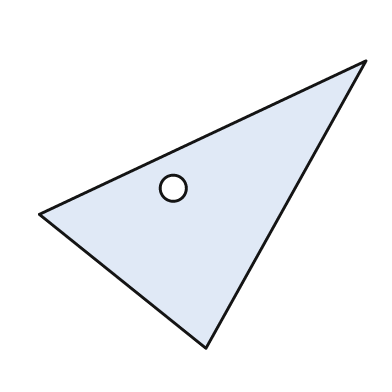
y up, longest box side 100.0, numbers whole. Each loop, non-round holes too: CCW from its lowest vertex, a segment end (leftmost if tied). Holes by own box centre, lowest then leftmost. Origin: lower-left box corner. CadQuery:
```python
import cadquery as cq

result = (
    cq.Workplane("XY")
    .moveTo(51.0, 0.0)
    .lineTo(100.0, 88.0)
    .lineTo(0.0, 41.0)
    .close()
    .moveTo(41.0, 49.0)
    .circle(4.0)
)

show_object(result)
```